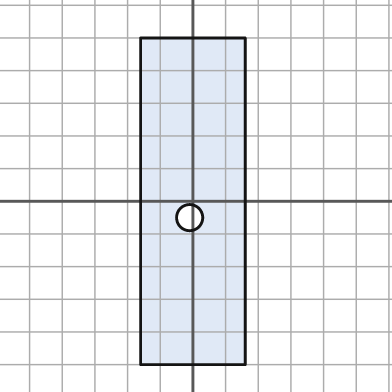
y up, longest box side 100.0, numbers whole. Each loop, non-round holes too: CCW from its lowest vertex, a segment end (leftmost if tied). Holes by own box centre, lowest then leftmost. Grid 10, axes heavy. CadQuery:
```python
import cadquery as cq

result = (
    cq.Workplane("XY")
    .moveTo(-16.0, -50.0)
    .lineTo(16.0, -50.0)
    .lineTo(16.0, 50.0)
    .lineTo(-16.0, 50.0)
    .close()
    .moveTo(-1.0, -5.0)
    .circle(4.0)
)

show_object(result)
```